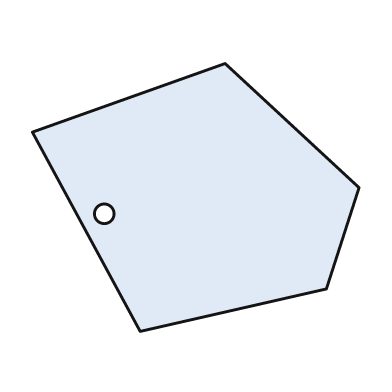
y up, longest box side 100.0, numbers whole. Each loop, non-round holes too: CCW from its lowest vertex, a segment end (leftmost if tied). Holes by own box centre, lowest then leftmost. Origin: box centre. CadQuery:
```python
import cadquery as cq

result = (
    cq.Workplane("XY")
    .moveTo(-17.0, -41.0)
    .lineTo(40.0, -28.0)
    .lineTo(50.0, 3.0)
    .lineTo(9.0, 41.0)
    .lineTo(-50.0, 20.0)
    .close()
    .moveTo(-28.0, -5.0)
    .circle(3.0)
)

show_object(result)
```